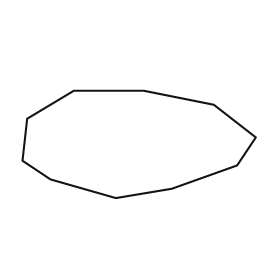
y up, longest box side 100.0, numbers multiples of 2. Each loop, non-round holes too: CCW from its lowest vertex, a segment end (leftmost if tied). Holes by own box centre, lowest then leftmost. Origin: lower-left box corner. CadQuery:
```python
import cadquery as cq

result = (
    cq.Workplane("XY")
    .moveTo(40.0, 0.0)
    .lineTo(64.0, 4.0)
    .lineTo(92.0, 14.0)
    .lineTo(100.0, 26.0)
    .lineTo(82.0, 40.0)
    .lineTo(52.0, 46.0)
    .lineTo(22.0, 46.0)
    .lineTo(2.0, 34.0)
    .lineTo(0.0, 16.0)
    .lineTo(12.0, 8.0)
    .close()
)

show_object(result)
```